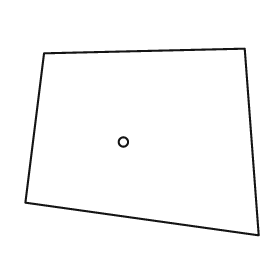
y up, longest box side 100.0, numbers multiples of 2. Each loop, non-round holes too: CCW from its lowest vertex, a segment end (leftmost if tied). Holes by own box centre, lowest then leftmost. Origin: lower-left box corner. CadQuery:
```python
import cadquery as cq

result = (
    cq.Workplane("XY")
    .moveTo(100.0, 0.0)
    .lineTo(94.0, 80.0)
    .lineTo(8.0, 78.0)
    .lineTo(0.0, 14.0)
    .close()
    .moveTo(42.0, 40.0)
    .circle(2.0)
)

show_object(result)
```